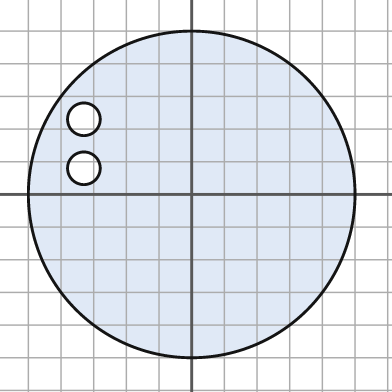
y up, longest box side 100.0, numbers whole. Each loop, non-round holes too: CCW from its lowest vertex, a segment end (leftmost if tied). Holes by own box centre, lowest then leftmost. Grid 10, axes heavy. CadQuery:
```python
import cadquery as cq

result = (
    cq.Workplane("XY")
    .moveTo(0.0, 0.0)
    .circle(50.0)
    .moveTo(-33.0, 8.0)
    .circle(5.0)
    .moveTo(-33.0, 23.0)
    .circle(5.0)
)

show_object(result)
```